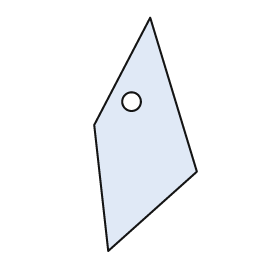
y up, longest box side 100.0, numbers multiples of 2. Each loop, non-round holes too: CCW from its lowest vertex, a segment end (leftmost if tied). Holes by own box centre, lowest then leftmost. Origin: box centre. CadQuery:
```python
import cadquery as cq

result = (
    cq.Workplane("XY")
    .moveTo(-16.0, -50.0)
    .lineTo(22.0, -16.0)
    .lineTo(2.0, 50.0)
    .lineTo(-22.0, 4.0)
    .close()
    .moveTo(-6.0, 14.0)
    .circle(4.0)
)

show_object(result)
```